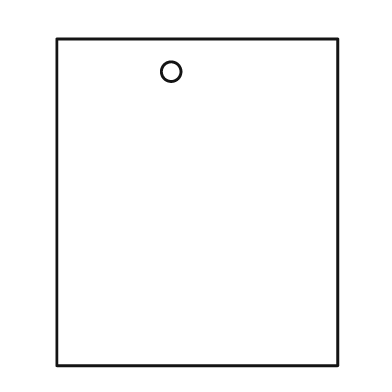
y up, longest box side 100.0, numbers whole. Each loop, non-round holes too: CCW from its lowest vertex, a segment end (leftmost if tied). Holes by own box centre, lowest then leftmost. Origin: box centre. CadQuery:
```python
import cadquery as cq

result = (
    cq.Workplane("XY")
    .moveTo(-43.0, -50.0)
    .lineTo(43.0, -50.0)
    .lineTo(43.0, 50.0)
    .lineTo(-43.0, 50.0)
    .close()
    .moveTo(-8.0, 40.0)
    .circle(3.0)
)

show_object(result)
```